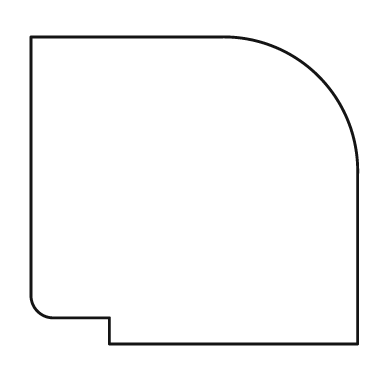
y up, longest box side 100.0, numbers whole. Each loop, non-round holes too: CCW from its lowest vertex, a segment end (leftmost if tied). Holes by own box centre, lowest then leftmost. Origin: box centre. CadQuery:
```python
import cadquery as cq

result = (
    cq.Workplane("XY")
    .moveTo(-26.0, -47.0)
    .lineTo(50.0, -47.0)
    .lineTo(50.0, 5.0)
    .threePointArc((38.0, 35.0), (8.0, 47.0))
    .lineTo(-50.0, 47.0)
    .lineTo(-50.0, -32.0)
    .threePointArc((-48.0, -37.0), (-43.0, -39.0))
    .lineTo(-26.0, -39.0)
    .close()
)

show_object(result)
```